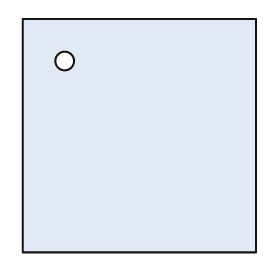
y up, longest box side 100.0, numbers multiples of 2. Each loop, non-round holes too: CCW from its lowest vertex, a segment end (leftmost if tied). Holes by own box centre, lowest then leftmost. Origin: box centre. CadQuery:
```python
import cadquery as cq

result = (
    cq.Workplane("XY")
    .moveTo(-50.0, -50.0)
    .lineTo(50.0, -50.0)
    .lineTo(50.0, 50.0)
    .lineTo(-50.0, 50.0)
    .close()
    .moveTo(-32.0, 32.0)
    .circle(4.0)
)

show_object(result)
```